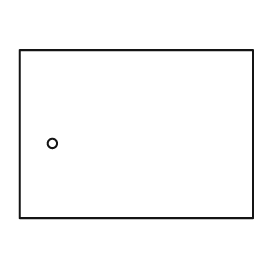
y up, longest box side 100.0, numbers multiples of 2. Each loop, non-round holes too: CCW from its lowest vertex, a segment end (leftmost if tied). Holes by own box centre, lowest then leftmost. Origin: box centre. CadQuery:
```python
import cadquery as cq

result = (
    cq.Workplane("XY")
    .moveTo(-50.0, -36.0)
    .lineTo(50.0, -36.0)
    .lineTo(50.0, 36.0)
    .lineTo(-50.0, 36.0)
    .close()
    .moveTo(-36.0, -4.0)
    .circle(2.0)
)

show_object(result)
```